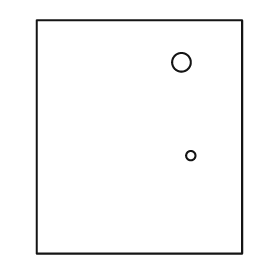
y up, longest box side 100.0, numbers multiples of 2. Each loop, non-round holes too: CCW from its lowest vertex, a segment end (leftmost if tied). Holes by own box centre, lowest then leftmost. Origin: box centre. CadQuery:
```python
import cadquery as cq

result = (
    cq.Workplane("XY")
    .moveTo(-44.0, -50.0)
    .lineTo(44.0, -50.0)
    .lineTo(44.0, 50.0)
    .lineTo(-44.0, 50.0)
    .close()
    .moveTo(22.0, -8.0)
    .circle(2.0)
    .moveTo(18.0, 32.0)
    .circle(4.0)
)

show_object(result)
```